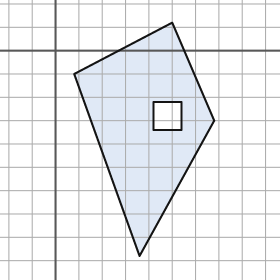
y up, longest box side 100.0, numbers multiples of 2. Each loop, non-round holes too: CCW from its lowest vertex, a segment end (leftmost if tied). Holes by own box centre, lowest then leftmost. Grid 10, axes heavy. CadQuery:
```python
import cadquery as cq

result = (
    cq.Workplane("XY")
    .moveTo(36.0, -88.0)
    .lineTo(68.0, -30.0)
    .lineTo(50.0, 12.0)
    .lineTo(8.0, -10.0)
    .close()
    .moveTo(42.0, -34.0)
    .lineTo(54.0, -34.0)
    .lineTo(54.0, -22.0)
    .lineTo(42.0, -22.0)
    .close()
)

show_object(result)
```